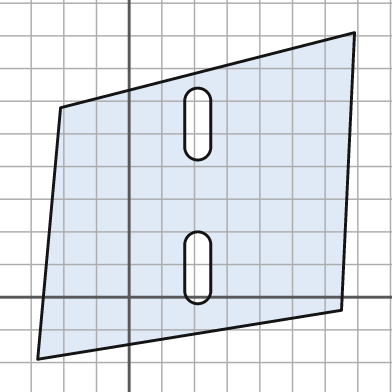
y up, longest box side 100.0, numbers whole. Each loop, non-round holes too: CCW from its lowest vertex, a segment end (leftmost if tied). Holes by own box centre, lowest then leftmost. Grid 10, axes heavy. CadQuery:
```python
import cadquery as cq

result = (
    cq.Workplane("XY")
    .moveTo(-28.0, -19.0)
    .lineTo(65.0, -4.0)
    .lineTo(69.0, 81.0)
    .lineTo(-21.0, 58.0)
    .close()
    .moveTo(17.0, 2.0)
    .threePointArc((21.0, -2.0), (25.0, 2.0))
    .lineTo(25.0, 16.0)
    .threePointArc((21.0, 20.0), (17.0, 16.0))
    .close()
    .moveTo(17.0, 46.0)
    .threePointArc((21.0, 42.0), (25.0, 46.0))
    .lineTo(25.0, 60.0)
    .threePointArc((21.0, 64.0), (17.0, 60.0))
    .close()
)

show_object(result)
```